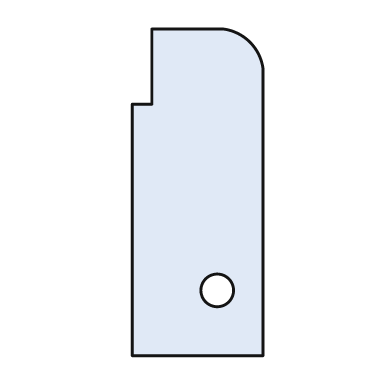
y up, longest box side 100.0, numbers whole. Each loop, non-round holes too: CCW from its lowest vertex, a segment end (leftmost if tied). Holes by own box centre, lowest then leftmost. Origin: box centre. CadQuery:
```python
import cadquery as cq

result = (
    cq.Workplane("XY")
    .moveTo(-20.0, -50.0)
    .lineTo(20.0, -50.0)
    .lineTo(20.0, 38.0)
    .threePointArc((16.0, 46.0), (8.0, 50.0))
    .lineTo(-14.0, 50.0)
    .lineTo(-14.0, 27.0)
    .lineTo(-20.0, 27.0)
    .close()
    .moveTo(6.0, -30.0)
    .circle(5.0)
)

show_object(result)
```